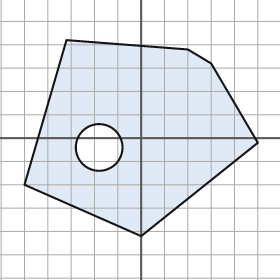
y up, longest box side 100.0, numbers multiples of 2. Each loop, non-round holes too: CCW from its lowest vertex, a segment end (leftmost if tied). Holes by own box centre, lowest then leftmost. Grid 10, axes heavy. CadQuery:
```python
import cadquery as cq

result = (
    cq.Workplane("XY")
    .moveTo(0.0, -42.0)
    .lineTo(50.0, -2.0)
    .lineTo(30.0, 32.0)
    .lineTo(20.0, 38.0)
    .lineTo(-32.0, 42.0)
    .lineTo(-50.0, -20.0)
    .close()
    .moveTo(-18.0, -4.0)
    .circle(10.0)
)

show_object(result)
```